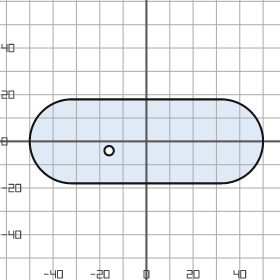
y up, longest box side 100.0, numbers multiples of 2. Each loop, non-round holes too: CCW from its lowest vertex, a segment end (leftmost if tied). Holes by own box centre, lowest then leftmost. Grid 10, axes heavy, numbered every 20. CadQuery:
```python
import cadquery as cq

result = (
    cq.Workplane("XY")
    .moveTo(-32.0, -18.0)
    .lineTo(32.0, -18.0)
    .threePointArc((50.0, 0.0), (32.0, 18.0))
    .lineTo(-32.0, 18.0)
    .threePointArc((-50.0, 0.0), (-32.0, -18.0))
    .close()
    .moveTo(-16.0, -4.0)
    .circle(2.0)
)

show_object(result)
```